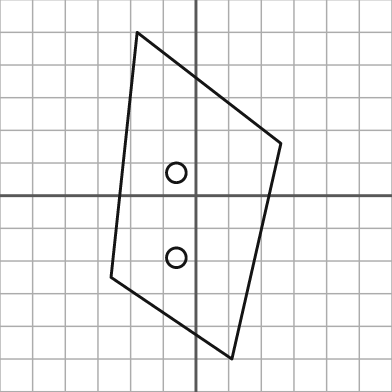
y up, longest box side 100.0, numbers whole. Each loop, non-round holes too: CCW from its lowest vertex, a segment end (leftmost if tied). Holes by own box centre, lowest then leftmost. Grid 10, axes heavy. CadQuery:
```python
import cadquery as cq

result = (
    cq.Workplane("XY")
    .moveTo(11.0, -50.0)
    .lineTo(26.0, 16.0)
    .lineTo(-18.0, 50.0)
    .lineTo(-26.0, -25.0)
    .close()
    .moveTo(-6.0, -19.0)
    .circle(3.0)
    .moveTo(-6.0, 7.0)
    .circle(3.0)
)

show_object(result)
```